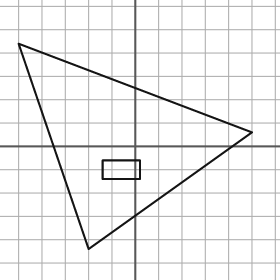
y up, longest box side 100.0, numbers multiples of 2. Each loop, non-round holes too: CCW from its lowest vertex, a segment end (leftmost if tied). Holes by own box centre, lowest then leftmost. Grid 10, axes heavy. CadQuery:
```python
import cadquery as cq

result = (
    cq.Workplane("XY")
    .moveTo(-20.0, -44.0)
    .lineTo(50.0, 6.0)
    .lineTo(-50.0, 44.0)
    .close()
    .moveTo(-14.0, -14.0)
    .lineTo(2.0, -14.0)
    .lineTo(2.0, -6.0)
    .lineTo(-14.0, -6.0)
    .close()
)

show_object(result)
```